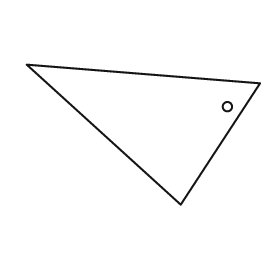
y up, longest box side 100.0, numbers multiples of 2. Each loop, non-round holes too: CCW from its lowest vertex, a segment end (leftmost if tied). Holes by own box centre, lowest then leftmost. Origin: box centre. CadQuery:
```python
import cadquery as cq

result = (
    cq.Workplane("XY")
    .moveTo(16.0, -30.0)
    .lineTo(50.0, 22.0)
    .lineTo(-50.0, 30.0)
    .close()
    .moveTo(36.0, 12.0)
    .circle(2.0)
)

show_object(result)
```